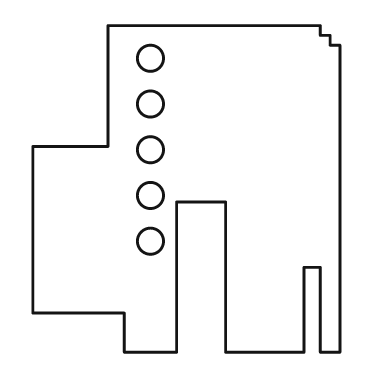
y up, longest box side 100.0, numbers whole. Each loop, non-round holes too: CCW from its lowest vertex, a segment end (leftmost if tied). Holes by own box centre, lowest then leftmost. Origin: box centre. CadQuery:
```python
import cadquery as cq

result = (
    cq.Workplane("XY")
    .moveTo(-19.0, -50.0)
    .lineTo(-3.0, -50.0)
    .lineTo(-3.0, -4.0)
    .lineTo(12.0, -4.0)
    .lineTo(12.0, -50.0)
    .lineTo(36.0, -50.0)
    .lineTo(36.0, -24.0)
    .lineTo(41.0, -24.0)
    .lineTo(41.0, -50.0)
    .lineTo(47.0, -50.0)
    .lineTo(47.0, 44.0)
    .lineTo(44.0, 44.0)
    .lineTo(44.0, 47.0)
    .lineTo(41.0, 47.0)
    .lineTo(41.0, 50.0)
    .lineTo(-24.0, 50.0)
    .lineTo(-24.0, 13.0)
    .lineTo(-47.0, 13.0)
    .lineTo(-47.0, -38.0)
    .lineTo(-19.0, -38.0)
    .close()
    .moveTo(-11.0, -16.0)
    .circle(4.0)
    .moveTo(-11.0, -2.0)
    .circle(4.0)
    .moveTo(-11.0, 12.0)
    .circle(4.0)
    .moveTo(-11.0, 26.0)
    .circle(4.0)
    .moveTo(-11.0, 40.0)
    .circle(4.0)
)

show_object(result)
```